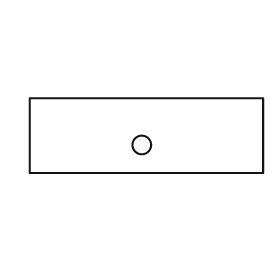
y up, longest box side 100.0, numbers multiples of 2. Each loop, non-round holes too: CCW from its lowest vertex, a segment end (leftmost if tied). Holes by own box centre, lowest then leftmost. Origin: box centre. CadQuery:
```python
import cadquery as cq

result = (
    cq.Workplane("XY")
    .moveTo(-50.0, -16.0)
    .lineTo(50.0, -16.0)
    .lineTo(50.0, 16.0)
    .lineTo(-50.0, 16.0)
    .close()
    .moveTo(-2.0, -4.0)
    .circle(4.0)
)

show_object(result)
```